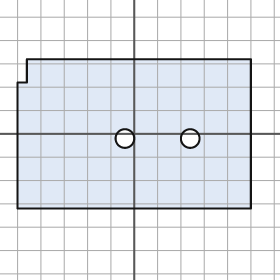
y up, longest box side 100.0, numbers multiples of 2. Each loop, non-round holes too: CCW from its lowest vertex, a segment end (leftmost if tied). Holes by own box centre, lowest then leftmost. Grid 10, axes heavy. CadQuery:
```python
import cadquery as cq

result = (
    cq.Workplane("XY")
    .moveTo(-50.0, -32.0)
    .lineTo(50.0, -32.0)
    .lineTo(50.0, 32.0)
    .lineTo(-46.0, 32.0)
    .lineTo(-46.0, 22.0)
    .lineTo(-50.0, 22.0)
    .close()
    .moveTo(-4.0, -2.0)
    .circle(4.0)
    .moveTo(24.0, -2.0)
    .circle(4.0)
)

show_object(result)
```